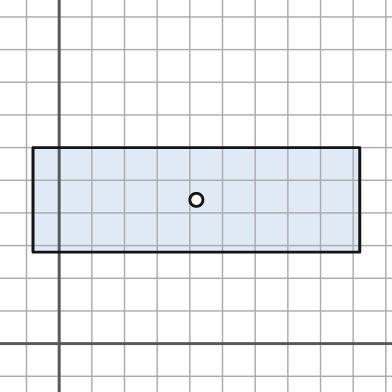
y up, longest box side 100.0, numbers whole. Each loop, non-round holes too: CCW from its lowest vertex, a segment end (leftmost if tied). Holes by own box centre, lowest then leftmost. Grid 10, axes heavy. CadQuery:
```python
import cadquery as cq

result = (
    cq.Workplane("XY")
    .moveTo(-8.0, 28.0)
    .lineTo(92.0, 28.0)
    .lineTo(92.0, 60.0)
    .lineTo(-8.0, 60.0)
    .close()
    .moveTo(42.0, 44.0)
    .circle(2.0)
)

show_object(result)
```